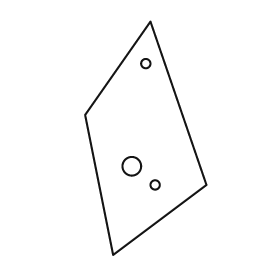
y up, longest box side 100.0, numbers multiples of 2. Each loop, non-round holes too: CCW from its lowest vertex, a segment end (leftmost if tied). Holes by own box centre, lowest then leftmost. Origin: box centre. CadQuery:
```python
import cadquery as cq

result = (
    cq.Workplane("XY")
    .moveTo(-14.0, -50.0)
    .lineTo(26.0, -20.0)
    .lineTo(2.0, 50.0)
    .lineTo(-26.0, 10.0)
    .close()
    .moveTo(4.0, -20.0)
    .circle(2.0)
    .moveTo(-6.0, -12.0)
    .circle(4.0)
    .moveTo(0.0, 32.0)
    .circle(2.0)
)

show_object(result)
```